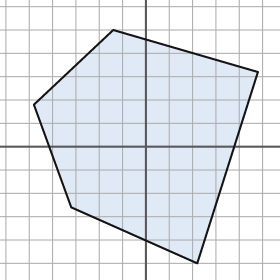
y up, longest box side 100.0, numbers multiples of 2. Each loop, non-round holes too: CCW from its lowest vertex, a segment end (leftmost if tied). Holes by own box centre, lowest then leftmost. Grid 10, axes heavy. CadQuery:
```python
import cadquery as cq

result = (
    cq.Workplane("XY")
    .moveTo(22.0, -50.0)
    .lineTo(48.0, 32.0)
    .lineTo(-14.0, 50.0)
    .lineTo(-48.0, 18.0)
    .lineTo(-32.0, -26.0)
    .close()
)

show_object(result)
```